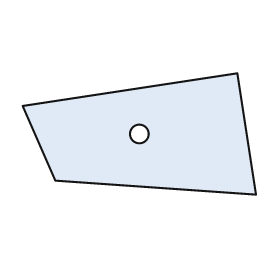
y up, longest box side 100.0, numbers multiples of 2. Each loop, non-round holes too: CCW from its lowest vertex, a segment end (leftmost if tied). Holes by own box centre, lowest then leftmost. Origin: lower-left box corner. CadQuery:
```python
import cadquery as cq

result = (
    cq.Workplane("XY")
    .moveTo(100.0, 0.0)
    .lineTo(92.0, 52.0)
    .lineTo(0.0, 38.0)
    .lineTo(14.0, 6.0)
    .close()
    .moveTo(50.0, 26.0)
    .circle(4.0)
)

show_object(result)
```